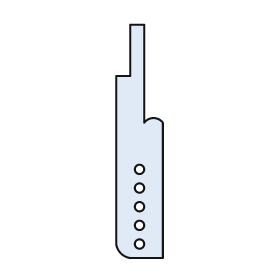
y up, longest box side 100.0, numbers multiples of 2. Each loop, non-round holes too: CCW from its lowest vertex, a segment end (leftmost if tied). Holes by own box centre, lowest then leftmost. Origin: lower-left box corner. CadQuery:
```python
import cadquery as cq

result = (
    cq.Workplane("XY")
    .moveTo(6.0, 0.0)
    .lineTo(20.0, 0.0)
    .lineTo(20.0, 58.0)
    .threePointArc((16.0, 60.0), (12.0, 58.0))
    .lineTo(12.0, 100.0)
    .lineTo(6.0, 100.0)
    .lineTo(6.0, 78.0)
    .lineTo(0.0, 78.0)
    .lineTo(0.0, 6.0)
    .threePointArc((2.0, 2.0), (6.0, 0.0))
    .close()
    .moveTo(10.0, 6.0)
    .circle(2.0)
    .moveTo(10.0, 14.0)
    .circle(2.0)
    .moveTo(10.0, 22.0)
    .circle(2.0)
    .moveTo(10.0, 30.0)
    .circle(2.0)
    .moveTo(10.0, 38.0)
    .circle(2.0)
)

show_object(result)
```